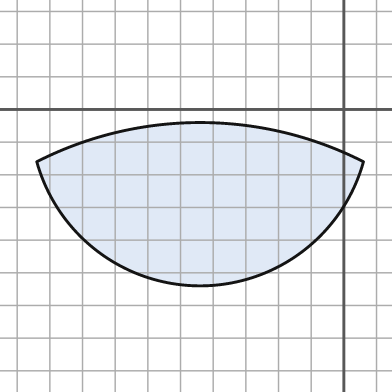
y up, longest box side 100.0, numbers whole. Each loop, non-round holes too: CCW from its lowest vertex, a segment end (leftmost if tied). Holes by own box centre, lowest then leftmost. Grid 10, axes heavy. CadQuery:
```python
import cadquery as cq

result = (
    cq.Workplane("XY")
    .moveTo(-94.0, -16.0)
    .threePointArc((-44.0, -54.0), (6.0, -16.0))
    .threePointArc((-44.0, -4.0), (-94.0, -16.0))
    .close()
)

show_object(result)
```